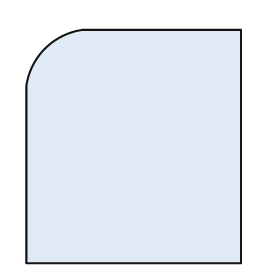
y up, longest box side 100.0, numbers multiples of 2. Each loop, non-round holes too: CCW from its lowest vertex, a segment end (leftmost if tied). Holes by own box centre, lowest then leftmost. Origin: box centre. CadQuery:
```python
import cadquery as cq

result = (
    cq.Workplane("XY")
    .moveTo(-46.0, -50.0)
    .lineTo(46.0, -50.0)
    .lineTo(46.0, 50.0)
    .lineTo(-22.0, 50.0)
    .threePointArc((-38.0, 42.0), (-46.0, 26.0))
    .close()
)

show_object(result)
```